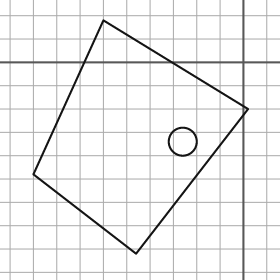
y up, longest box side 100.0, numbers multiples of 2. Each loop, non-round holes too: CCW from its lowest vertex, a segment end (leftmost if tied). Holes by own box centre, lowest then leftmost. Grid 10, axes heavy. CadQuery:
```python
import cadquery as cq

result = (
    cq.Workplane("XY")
    .moveTo(-46.0, -82.0)
    .lineTo(2.0, -20.0)
    .lineTo(-60.0, 18.0)
    .lineTo(-90.0, -48.0)
    .close()
    .moveTo(-26.0, -34.0)
    .circle(6.0)
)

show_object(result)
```